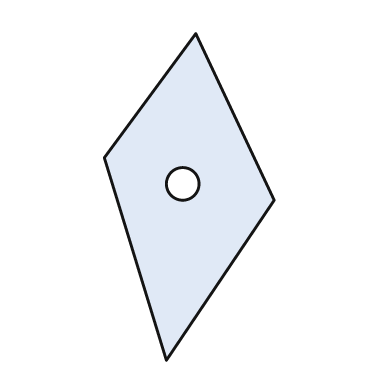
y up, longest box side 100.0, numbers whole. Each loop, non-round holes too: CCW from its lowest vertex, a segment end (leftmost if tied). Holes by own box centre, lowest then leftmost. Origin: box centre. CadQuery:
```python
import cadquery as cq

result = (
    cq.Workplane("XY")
    .moveTo(-7.0, -50.0)
    .lineTo(26.0, -1.0)
    .lineTo(2.0, 50.0)
    .lineTo(-26.0, 12.0)
    .close()
    .moveTo(-2.0, 4.0)
    .circle(5.0)
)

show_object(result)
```